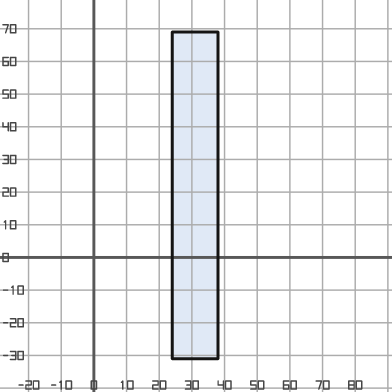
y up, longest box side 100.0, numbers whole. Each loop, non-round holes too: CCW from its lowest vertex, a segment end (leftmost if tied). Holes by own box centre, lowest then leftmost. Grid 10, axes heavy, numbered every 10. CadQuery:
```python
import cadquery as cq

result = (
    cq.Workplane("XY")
    .moveTo(24.0, -31.0)
    .lineTo(38.0, -31.0)
    .lineTo(38.0, 69.0)
    .lineTo(24.0, 69.0)
    .close()
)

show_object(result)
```